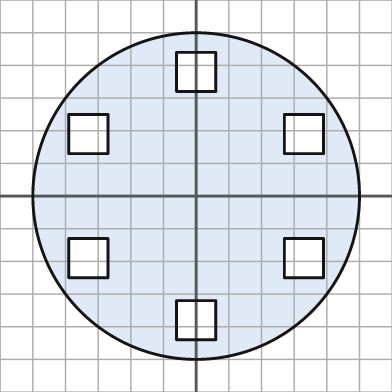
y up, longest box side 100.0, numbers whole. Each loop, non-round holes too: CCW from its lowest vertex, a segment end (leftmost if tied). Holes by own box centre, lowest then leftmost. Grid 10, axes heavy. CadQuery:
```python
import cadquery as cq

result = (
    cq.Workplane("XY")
    .moveTo(0.0, 0.0)
    .circle(50.0)
    .moveTo(-6.0, -44.0)
    .lineTo(6.0, -44.0)
    .lineTo(6.0, -32.0)
    .lineTo(-6.0, -32.0)
    .close()
    .moveTo(-39.0, -25.0)
    .lineTo(-27.0, -25.0)
    .lineTo(-27.0, -13.0)
    .lineTo(-39.0, -13.0)
    .close()
    .moveTo(27.0, -25.0)
    .lineTo(39.0, -25.0)
    .lineTo(39.0, -13.0)
    .lineTo(27.0, -13.0)
    .close()
    .moveTo(-39.0, 13.0)
    .lineTo(-27.0, 13.0)
    .lineTo(-27.0, 25.0)
    .lineTo(-39.0, 25.0)
    .close()
    .moveTo(27.0, 13.0)
    .lineTo(39.0, 13.0)
    .lineTo(39.0, 25.0)
    .lineTo(27.0, 25.0)
    .close()
    .moveTo(-6.0, 32.0)
    .lineTo(6.0, 32.0)
    .lineTo(6.0, 44.0)
    .lineTo(-6.0, 44.0)
    .close()
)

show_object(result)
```